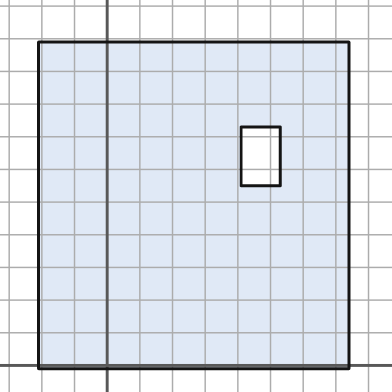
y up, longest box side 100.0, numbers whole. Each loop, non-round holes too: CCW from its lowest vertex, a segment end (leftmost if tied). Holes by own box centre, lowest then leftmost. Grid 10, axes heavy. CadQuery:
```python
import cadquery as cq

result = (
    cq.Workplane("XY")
    .moveTo(-21.0, -1.0)
    .lineTo(74.0, -1.0)
    .lineTo(74.0, 99.0)
    .lineTo(-21.0, 99.0)
    .close()
    .moveTo(41.0, 55.0)
    .lineTo(53.0, 55.0)
    .lineTo(53.0, 73.0)
    .lineTo(41.0, 73.0)
    .close()
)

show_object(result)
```